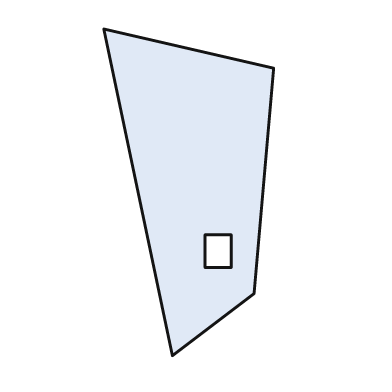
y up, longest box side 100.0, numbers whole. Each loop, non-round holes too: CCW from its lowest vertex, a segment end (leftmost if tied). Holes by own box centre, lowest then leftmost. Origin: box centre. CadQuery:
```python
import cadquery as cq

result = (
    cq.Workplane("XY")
    .moveTo(-5.0, -50.0)
    .lineTo(20.0, -31.0)
    .lineTo(26.0, 38.0)
    .lineTo(-26.0, 50.0)
    .close()
    .moveTo(5.0, -23.0)
    .lineTo(13.0, -23.0)
    .lineTo(13.0, -13.0)
    .lineTo(5.0, -13.0)
    .close()
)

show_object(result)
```